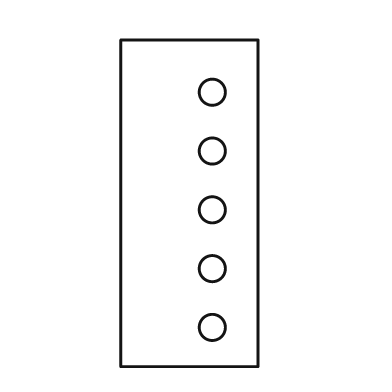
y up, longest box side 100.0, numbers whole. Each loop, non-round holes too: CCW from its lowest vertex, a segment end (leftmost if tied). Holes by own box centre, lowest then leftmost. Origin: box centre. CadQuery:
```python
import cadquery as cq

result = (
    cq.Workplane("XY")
    .moveTo(-21.0, -50.0)
    .lineTo(21.0, -50.0)
    .lineTo(21.0, 50.0)
    .lineTo(-21.0, 50.0)
    .close()
    .moveTo(7.0, -38.0)
    .circle(4.0)
    .moveTo(7.0, -20.0)
    .circle(4.0)
    .moveTo(7.0, -2.0)
    .circle(4.0)
    .moveTo(7.0, 16.0)
    .circle(4.0)
    .moveTo(7.0, 34.0)
    .circle(4.0)
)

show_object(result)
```